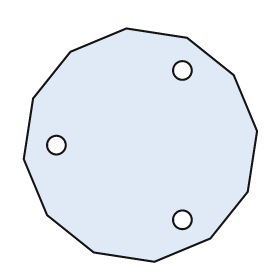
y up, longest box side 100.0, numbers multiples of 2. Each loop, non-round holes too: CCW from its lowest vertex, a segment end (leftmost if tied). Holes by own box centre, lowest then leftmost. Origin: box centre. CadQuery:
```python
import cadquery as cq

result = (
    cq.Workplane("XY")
    .moveTo(6.0, -50.0)
    .lineTo(30.0, -40.0)
    .lineTo(46.0, -20.0)
    .lineTo(50.0, 6.0)
    .lineTo(40.0, 30.0)
    .lineTo(20.0, 46.0)
    .lineTo(-6.0, 50.0)
    .lineTo(-30.0, 40.0)
    .lineTo(-46.0, 20.0)
    .lineTo(-50.0, -6.0)
    .lineTo(-40.0, -30.0)
    .lineTo(-20.0, -46.0)
    .close()
    .moveTo(18.0, -32.0)
    .circle(4.0)
    .moveTo(-36.0, 0.0)
    .circle(4.0)
    .moveTo(18.0, 32.0)
    .circle(4.0)
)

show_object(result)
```